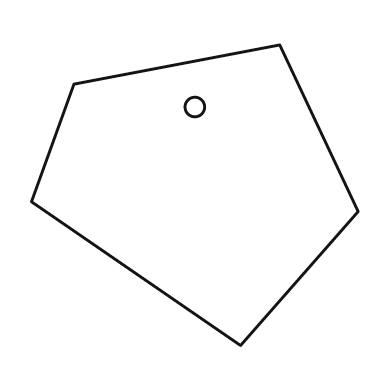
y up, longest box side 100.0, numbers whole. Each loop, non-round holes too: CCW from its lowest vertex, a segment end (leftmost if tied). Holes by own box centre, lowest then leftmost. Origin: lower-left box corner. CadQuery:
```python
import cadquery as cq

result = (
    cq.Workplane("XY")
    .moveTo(64.0, 0.0)
    .lineTo(100.0, 41.0)
    .lineTo(76.0, 92.0)
    .lineTo(13.0, 80.0)
    .lineTo(0.0, 44.0)
    .close()
    .moveTo(50.0, 73.0)
    .circle(3.0)
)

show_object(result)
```